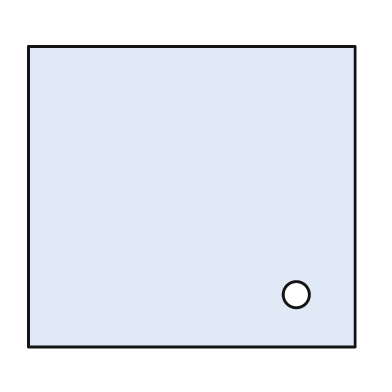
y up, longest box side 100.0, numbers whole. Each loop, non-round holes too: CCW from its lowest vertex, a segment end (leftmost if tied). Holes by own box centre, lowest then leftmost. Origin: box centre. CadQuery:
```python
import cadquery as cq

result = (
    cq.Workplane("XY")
    .moveTo(-50.0, -46.0)
    .lineTo(50.0, -46.0)
    .lineTo(50.0, 46.0)
    .lineTo(-50.0, 46.0)
    .close()
    .moveTo(32.0, -30.0)
    .circle(4.0)
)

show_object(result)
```